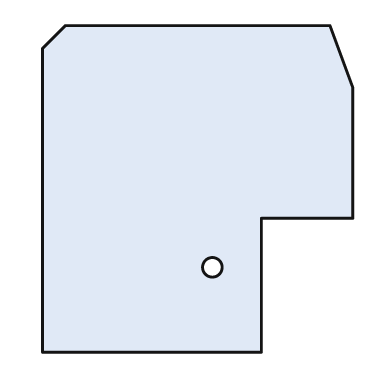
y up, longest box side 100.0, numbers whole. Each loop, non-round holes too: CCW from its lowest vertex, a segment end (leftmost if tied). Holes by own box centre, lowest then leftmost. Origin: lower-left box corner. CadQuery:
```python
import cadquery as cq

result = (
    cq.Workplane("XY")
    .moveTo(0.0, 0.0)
    .lineTo(67.0, 0.0)
    .lineTo(67.0, 41.0)
    .lineTo(95.0, 41.0)
    .lineTo(95.0, 81.0)
    .lineTo(88.0, 100.0)
    .lineTo(7.0, 100.0)
    .lineTo(0.0, 93.0)
    .close()
    .moveTo(52.0, 26.0)
    .circle(3.0)
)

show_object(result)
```